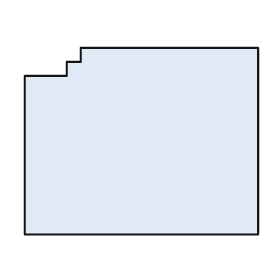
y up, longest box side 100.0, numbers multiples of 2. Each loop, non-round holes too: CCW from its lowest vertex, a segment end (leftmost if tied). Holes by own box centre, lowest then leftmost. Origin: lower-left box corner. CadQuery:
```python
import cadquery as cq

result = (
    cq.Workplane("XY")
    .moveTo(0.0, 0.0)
    .lineTo(100.0, 0.0)
    .lineTo(100.0, 80.0)
    .lineTo(24.0, 80.0)
    .lineTo(24.0, 74.0)
    .lineTo(18.0, 74.0)
    .lineTo(18.0, 68.0)
    .lineTo(0.0, 68.0)
    .close()
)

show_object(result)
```